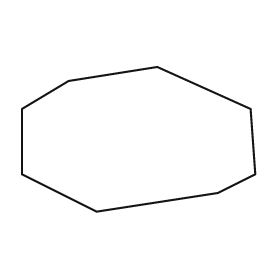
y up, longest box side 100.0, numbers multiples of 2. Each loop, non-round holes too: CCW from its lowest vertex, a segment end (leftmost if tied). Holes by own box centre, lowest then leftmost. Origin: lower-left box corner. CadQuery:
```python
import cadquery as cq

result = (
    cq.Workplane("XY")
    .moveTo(32.0, 0.0)
    .lineTo(84.0, 8.0)
    .lineTo(100.0, 16.0)
    .lineTo(98.0, 44.0)
    .lineTo(58.0, 62.0)
    .lineTo(20.0, 56.0)
    .lineTo(0.0, 44.0)
    .lineTo(0.0, 16.0)
    .close()
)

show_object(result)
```